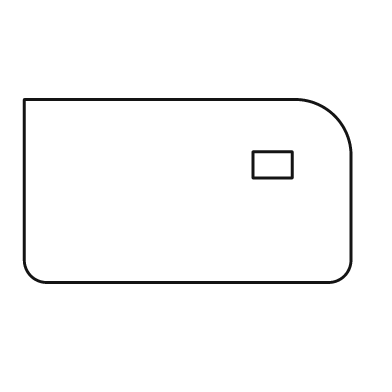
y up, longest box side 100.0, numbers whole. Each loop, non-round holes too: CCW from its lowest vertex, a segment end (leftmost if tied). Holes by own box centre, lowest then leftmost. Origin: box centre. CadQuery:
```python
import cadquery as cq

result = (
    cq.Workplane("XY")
    .moveTo(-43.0, -28.0)
    .lineTo(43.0, -28.0)
    .threePointArc((48.0, -26.0), (50.0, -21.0))
    .lineTo(50.0, 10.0)
    .threePointArc((45.0, 23.0), (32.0, 28.0))
    .lineTo(-50.0, 28.0)
    .lineTo(-50.0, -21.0)
    .threePointArc((-48.0, -26.0), (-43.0, -28.0))
    .close()
    .moveTo(20.0, 4.0)
    .lineTo(32.0, 4.0)
    .lineTo(32.0, 12.0)
    .lineTo(20.0, 12.0)
    .close()
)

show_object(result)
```